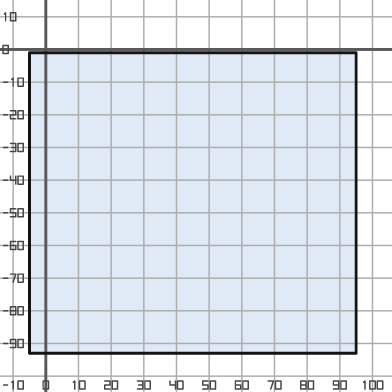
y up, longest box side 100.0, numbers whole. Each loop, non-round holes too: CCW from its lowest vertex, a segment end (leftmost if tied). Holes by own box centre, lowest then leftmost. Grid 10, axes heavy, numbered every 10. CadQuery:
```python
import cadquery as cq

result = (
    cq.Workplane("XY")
    .moveTo(-5.0, -93.0)
    .lineTo(95.0, -93.0)
    .lineTo(95.0, -1.0)
    .lineTo(-5.0, -1.0)
    .close()
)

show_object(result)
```